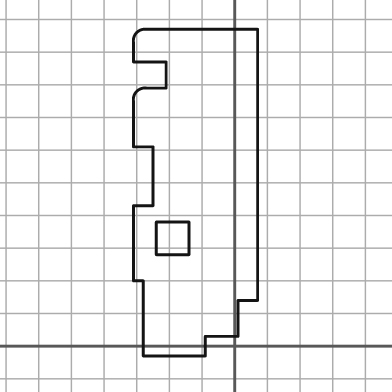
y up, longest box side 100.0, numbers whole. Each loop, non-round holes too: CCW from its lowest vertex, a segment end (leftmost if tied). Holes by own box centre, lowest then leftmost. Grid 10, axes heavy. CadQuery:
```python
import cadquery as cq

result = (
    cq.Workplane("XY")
    .moveTo(-28.0, -3.0)
    .lineTo(-9.0, -3.0)
    .lineTo(-9.0, 3.0)
    .lineTo(1.0, 3.0)
    .lineTo(1.0, 14.0)
    .lineTo(7.0, 14.0)
    .lineTo(7.0, 97.0)
    .lineTo(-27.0, 97.0)
    .threePointArc((-30.0, 96.0), (-31.0, 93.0))
    .lineTo(-31.0, 87.0)
    .lineTo(-21.0, 87.0)
    .lineTo(-21.0, 79.0)
    .lineTo(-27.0, 79.0)
    .threePointArc((-30.0, 78.0), (-31.0, 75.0))
    .lineTo(-31.0, 61.0)
    .lineTo(-25.0, 61.0)
    .lineTo(-25.0, 43.0)
    .lineTo(-31.0, 43.0)
    .lineTo(-31.0, 20.0)
    .lineTo(-28.0, 20.0)
    .close()
    .moveTo(-24.0, 28.0)
    .lineTo(-14.0, 28.0)
    .lineTo(-14.0, 38.0)
    .lineTo(-24.0, 38.0)
    .close()
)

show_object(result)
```